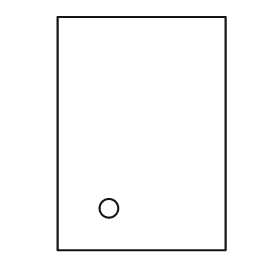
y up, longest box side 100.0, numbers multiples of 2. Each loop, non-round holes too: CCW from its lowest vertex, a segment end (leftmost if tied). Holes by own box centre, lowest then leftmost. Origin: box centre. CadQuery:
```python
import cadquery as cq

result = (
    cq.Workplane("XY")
    .moveTo(-36.0, -50.0)
    .lineTo(36.0, -50.0)
    .lineTo(36.0, 50.0)
    .lineTo(-36.0, 50.0)
    .close()
    .moveTo(-14.0, -32.0)
    .circle(4.0)
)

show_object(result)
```